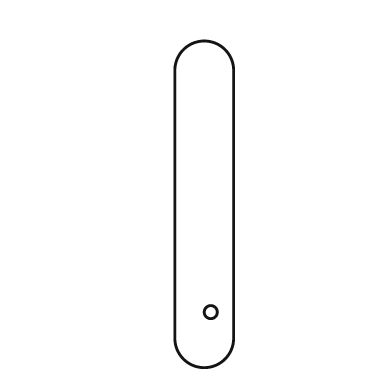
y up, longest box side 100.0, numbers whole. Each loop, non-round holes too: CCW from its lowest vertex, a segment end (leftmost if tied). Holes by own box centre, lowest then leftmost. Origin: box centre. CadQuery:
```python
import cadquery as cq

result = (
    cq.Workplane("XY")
    .moveTo(-9.0, -41.0)
    .threePointArc((0.0, -50.0), (9.0, -41.0))
    .lineTo(9.0, 41.0)
    .threePointArc((0.0, 50.0), (-9.0, 41.0))
    .close()
    .moveTo(2.0, -33.0)
    .circle(2.0)
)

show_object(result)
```